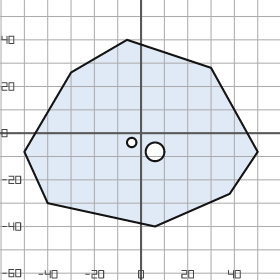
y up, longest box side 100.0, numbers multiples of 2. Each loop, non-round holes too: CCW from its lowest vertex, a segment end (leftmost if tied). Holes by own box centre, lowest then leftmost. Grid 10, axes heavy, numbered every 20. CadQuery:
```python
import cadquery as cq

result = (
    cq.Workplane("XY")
    .moveTo(6.0, -40.0)
    .lineTo(38.0, -26.0)
    .lineTo(50.0, -8.0)
    .lineTo(30.0, 28.0)
    .lineTo(-6.0, 40.0)
    .lineTo(-30.0, 26.0)
    .lineTo(-50.0, -8.0)
    .lineTo(-40.0, -30.0)
    .close()
    .moveTo(6.0, -8.0)
    .circle(4.0)
    .moveTo(-4.0, -4.0)
    .circle(2.0)
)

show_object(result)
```